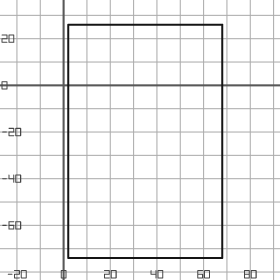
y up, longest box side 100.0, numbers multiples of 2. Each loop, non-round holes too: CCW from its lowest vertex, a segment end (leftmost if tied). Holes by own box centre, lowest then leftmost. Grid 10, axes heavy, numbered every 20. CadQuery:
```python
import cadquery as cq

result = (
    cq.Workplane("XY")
    .moveTo(2.0, -74.0)
    .lineTo(68.0, -74.0)
    .lineTo(68.0, 26.0)
    .lineTo(2.0, 26.0)
    .close()
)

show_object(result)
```